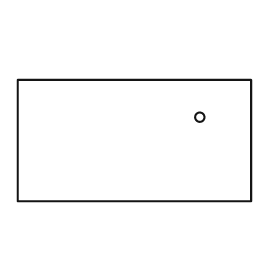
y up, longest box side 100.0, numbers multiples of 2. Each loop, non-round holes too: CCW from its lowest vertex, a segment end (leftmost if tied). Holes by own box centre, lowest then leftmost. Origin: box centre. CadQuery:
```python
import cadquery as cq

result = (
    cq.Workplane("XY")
    .moveTo(-50.0, -26.0)
    .lineTo(50.0, -26.0)
    .lineTo(50.0, 26.0)
    .lineTo(-50.0, 26.0)
    .close()
    .moveTo(28.0, 10.0)
    .circle(2.0)
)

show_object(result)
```